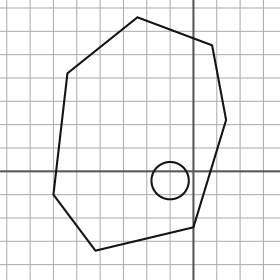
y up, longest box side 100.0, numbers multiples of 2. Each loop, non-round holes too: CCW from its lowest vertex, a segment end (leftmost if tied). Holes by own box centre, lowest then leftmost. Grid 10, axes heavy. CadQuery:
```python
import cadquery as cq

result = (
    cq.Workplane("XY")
    .moveTo(-42.0, -34.0)
    .lineTo(0.0, -24.0)
    .lineTo(14.0, 22.0)
    .lineTo(8.0, 54.0)
    .lineTo(-24.0, 66.0)
    .lineTo(-54.0, 42.0)
    .lineTo(-60.0, -10.0)
    .close()
    .moveTo(-10.0, -4.0)
    .circle(8.0)
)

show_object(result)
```